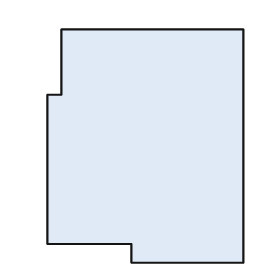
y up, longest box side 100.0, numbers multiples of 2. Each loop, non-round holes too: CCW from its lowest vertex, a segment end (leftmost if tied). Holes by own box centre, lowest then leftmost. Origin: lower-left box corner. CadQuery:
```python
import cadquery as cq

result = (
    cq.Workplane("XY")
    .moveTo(36.0, 0.0)
    .lineTo(84.0, 0.0)
    .lineTo(84.0, 100.0)
    .lineTo(6.0, 100.0)
    .lineTo(6.0, 72.0)
    .lineTo(0.0, 72.0)
    .lineTo(0.0, 8.0)
    .lineTo(36.0, 8.0)
    .close()
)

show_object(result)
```